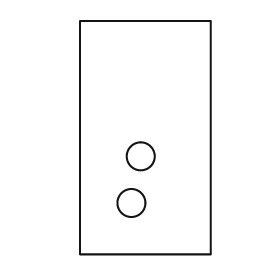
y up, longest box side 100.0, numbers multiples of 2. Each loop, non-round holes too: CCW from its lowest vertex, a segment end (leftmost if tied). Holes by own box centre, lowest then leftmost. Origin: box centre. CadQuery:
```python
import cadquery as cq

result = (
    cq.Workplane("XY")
    .moveTo(-28.0, -50.0)
    .lineTo(28.0, -50.0)
    .lineTo(28.0, 50.0)
    .lineTo(-28.0, 50.0)
    .close()
    .moveTo(-6.0, -28.0)
    .circle(6.0)
    .moveTo(-2.0, -8.0)
    .circle(6.0)
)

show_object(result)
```